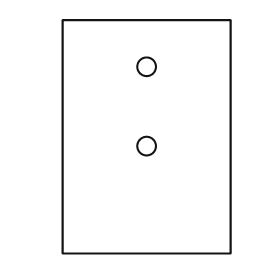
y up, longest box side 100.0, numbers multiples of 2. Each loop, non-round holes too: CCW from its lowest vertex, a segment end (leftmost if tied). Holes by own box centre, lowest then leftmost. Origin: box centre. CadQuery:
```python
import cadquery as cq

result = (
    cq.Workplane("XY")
    .moveTo(-36.0, -50.0)
    .lineTo(36.0, -50.0)
    .lineTo(36.0, 50.0)
    .lineTo(-36.0, 50.0)
    .close()
    .moveTo(0.0, -4.0)
    .circle(4.0)
    .moveTo(0.0, 30.0)
    .circle(4.0)
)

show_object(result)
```